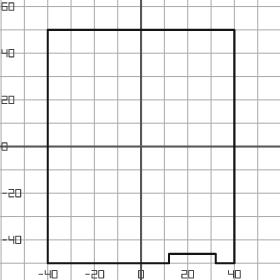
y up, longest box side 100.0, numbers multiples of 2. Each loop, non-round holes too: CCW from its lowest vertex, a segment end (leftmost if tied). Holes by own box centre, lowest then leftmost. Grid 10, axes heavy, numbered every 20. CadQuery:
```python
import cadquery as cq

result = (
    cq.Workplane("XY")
    .moveTo(-40.0, -50.0)
    .lineTo(12.0, -50.0)
    .lineTo(12.0, -46.0)
    .lineTo(32.0, -46.0)
    .lineTo(32.0, -50.0)
    .lineTo(40.0, -50.0)
    .lineTo(40.0, 50.0)
    .lineTo(-40.0, 50.0)
    .close()
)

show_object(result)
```